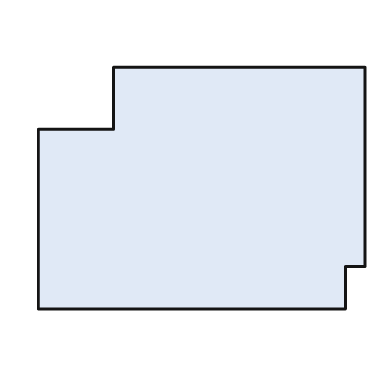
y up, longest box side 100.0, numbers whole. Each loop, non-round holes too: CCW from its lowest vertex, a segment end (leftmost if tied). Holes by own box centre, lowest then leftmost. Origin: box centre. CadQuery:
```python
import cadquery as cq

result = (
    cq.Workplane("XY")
    .moveTo(-50.0, -37.0)
    .lineTo(44.0, -37.0)
    .lineTo(44.0, -24.0)
    .lineTo(50.0, -24.0)
    .lineTo(50.0, 37.0)
    .lineTo(-27.0, 37.0)
    .lineTo(-27.0, 18.0)
    .lineTo(-50.0, 18.0)
    .close()
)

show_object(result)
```